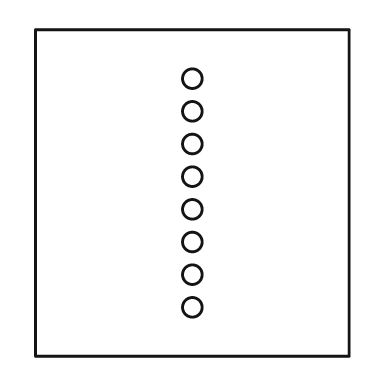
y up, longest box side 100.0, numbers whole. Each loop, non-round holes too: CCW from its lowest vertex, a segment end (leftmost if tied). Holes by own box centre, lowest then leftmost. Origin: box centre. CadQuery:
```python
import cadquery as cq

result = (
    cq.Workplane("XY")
    .moveTo(-48.0, -50.0)
    .lineTo(48.0, -50.0)
    .lineTo(48.0, 50.0)
    .lineTo(-48.0, 50.0)
    .close()
    .moveTo(0.0, -35.0)
    .circle(3.0)
    .moveTo(0.0, -25.0)
    .circle(3.0)
    .moveTo(0.0, -15.0)
    .circle(3.0)
    .moveTo(0.0, -5.0)
    .circle(3.0)
    .moveTo(0.0, 5.0)
    .circle(3.0)
    .moveTo(0.0, 15.0)
    .circle(3.0)
    .moveTo(0.0, 25.0)
    .circle(3.0)
    .moveTo(0.0, 35.0)
    .circle(3.0)
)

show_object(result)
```